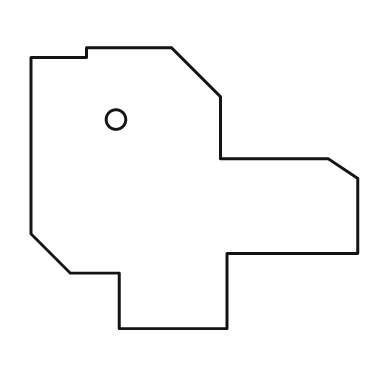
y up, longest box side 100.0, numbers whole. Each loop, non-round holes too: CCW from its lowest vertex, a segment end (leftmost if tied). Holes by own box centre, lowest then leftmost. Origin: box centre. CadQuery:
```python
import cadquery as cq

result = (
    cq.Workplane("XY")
    .moveTo(-23.0, -43.0)
    .lineTo(10.0, -43.0)
    .lineTo(10.0, -20.0)
    .lineTo(50.0, -20.0)
    .lineTo(50.0, 3.0)
    .lineTo(41.0, 9.0)
    .lineTo(8.0, 9.0)
    .lineTo(8.0, 28.0)
    .lineTo(-7.0, 43.0)
    .lineTo(-33.0, 43.0)
    .lineTo(-33.0, 40.0)
    .lineTo(-50.0, 40.0)
    .lineTo(-50.0, -14.0)
    .lineTo(-38.0, -26.0)
    .lineTo(-23.0, -26.0)
    .close()
    .moveTo(-24.0, 21.0)
    .circle(3.0)
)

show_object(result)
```